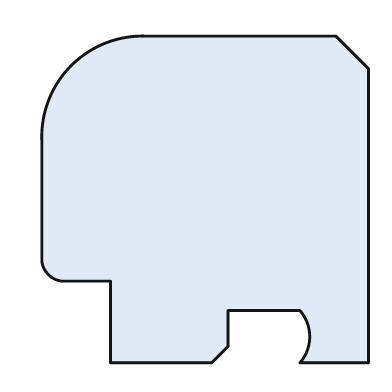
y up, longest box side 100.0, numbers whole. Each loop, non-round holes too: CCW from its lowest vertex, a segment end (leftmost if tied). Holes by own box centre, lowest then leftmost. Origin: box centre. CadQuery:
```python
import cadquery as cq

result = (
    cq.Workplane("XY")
    .moveTo(-29.0, -50.0)
    .lineTo(2.0, -50.0)
    .lineTo(7.0, -45.0)
    .lineTo(7.0, -34.0)
    .lineTo(29.0, -34.0)
    .threePointArc((32.0, -42.0), (29.0, -50.0))
    .lineTo(50.0, -50.0)
    .lineTo(50.0, 40.0)
    .lineTo(40.0, 50.0)
    .lineTo(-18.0, 50.0)
    .threePointArc((-41.0, 41.0), (-50.0, 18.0))
    .lineTo(-50.0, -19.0)
    .threePointArc((-48.0, -23.0), (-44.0, -25.0))
    .lineTo(-29.0, -25.0)
    .close()
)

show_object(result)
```